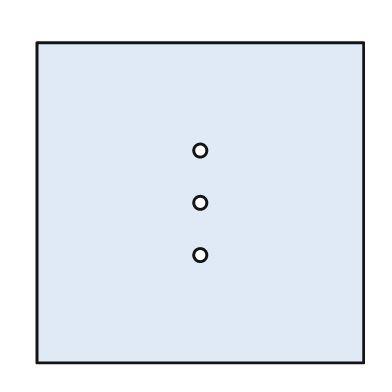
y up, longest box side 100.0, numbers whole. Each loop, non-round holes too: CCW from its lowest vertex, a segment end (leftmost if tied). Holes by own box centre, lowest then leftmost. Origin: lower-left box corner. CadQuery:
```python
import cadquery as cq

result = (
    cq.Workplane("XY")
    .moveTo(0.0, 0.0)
    .lineTo(100.0, 0.0)
    .lineTo(100.0, 98.0)
    .lineTo(0.0, 98.0)
    .close()
    .moveTo(50.0, 33.0)
    .circle(2.0)
    .moveTo(50.0, 49.0)
    .circle(2.0)
    .moveTo(50.0, 65.0)
    .circle(2.0)
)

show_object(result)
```